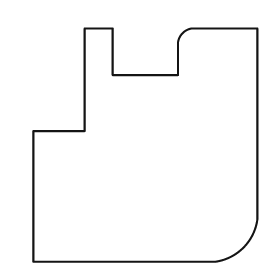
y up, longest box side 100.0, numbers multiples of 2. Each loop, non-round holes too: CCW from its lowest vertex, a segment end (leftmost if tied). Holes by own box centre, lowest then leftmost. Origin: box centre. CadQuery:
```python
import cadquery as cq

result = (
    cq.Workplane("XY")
    .moveTo(-48.0, -50.0)
    .lineTo(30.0, -50.0)
    .threePointArc((42.0, -44.0), (48.0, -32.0))
    .lineTo(48.0, 50.0)
    .lineTo(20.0, 50.0)
    .threePointArc((16.0, 48.0), (14.0, 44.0))
    .lineTo(14.0, 30.0)
    .lineTo(-14.0, 30.0)
    .lineTo(-14.0, 50.0)
    .lineTo(-26.0, 50.0)
    .lineTo(-26.0, 6.0)
    .lineTo(-48.0, 6.0)
    .close()
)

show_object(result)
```